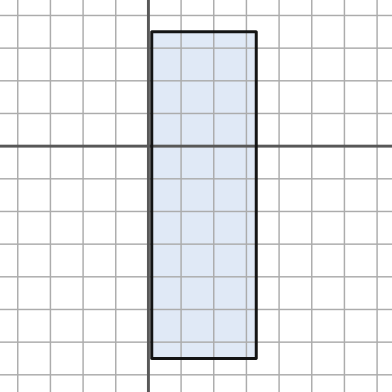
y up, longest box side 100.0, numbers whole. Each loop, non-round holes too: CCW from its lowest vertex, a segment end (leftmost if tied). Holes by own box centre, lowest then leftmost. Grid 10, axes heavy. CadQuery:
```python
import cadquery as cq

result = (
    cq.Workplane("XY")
    .moveTo(1.0, -65.0)
    .lineTo(33.0, -65.0)
    .lineTo(33.0, 35.0)
    .lineTo(1.0, 35.0)
    .close()
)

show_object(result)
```